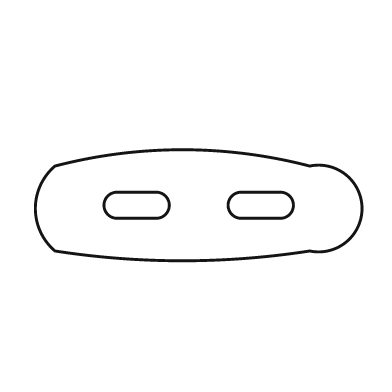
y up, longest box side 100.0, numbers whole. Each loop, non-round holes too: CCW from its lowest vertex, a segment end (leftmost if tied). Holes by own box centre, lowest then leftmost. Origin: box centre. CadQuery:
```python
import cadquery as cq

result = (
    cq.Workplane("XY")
    .moveTo(-44.0, -14.0)
    .threePointArc((-5.0, -17.0), (34.0, -14.0))
    .threePointArc((50.0, -1.0), (34.0, 12.0))
    .threePointArc((-5.0, 17.0), (-44.0, 12.0))
    .threePointArc((-50.0, -1.0), (-44.0, -14.0))
    .close()
    .moveTo(-25.0, -4.0)
    .lineTo(-13.0, -4.0)
    .threePointArc((-9.0, 0.0), (-13.0, 4.0))
    .lineTo(-25.0, 4.0)
    .threePointArc((-29.0, 0.0), (-25.0, -4.0))
    .close()
    .moveTo(13.0, -4.0)
    .lineTo(25.0, -4.0)
    .threePointArc((29.0, 0.0), (25.0, 4.0))
    .lineTo(13.0, 4.0)
    .threePointArc((9.0, 0.0), (13.0, -4.0))
    .close()
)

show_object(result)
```